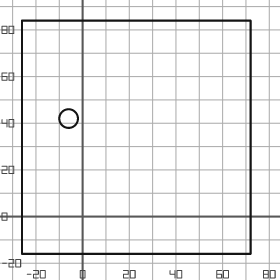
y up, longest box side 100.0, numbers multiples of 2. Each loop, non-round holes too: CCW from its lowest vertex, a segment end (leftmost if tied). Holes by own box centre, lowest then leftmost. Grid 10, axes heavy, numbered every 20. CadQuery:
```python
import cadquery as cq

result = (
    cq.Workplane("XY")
    .moveTo(-26.0, -16.0)
    .lineTo(72.0, -16.0)
    .lineTo(72.0, 84.0)
    .lineTo(-26.0, 84.0)
    .close()
    .moveTo(-6.0, 42.0)
    .circle(4.0)
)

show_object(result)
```